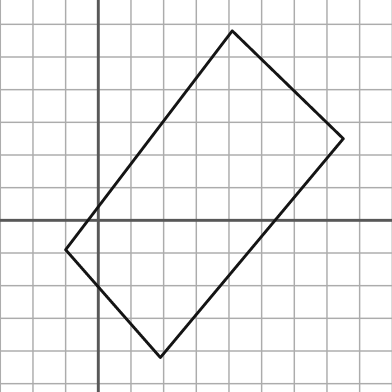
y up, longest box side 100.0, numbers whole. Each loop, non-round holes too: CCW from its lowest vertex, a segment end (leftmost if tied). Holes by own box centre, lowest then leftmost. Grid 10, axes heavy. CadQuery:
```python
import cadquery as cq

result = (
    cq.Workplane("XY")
    .moveTo(19.0, -42.0)
    .lineTo(75.0, 25.0)
    .lineTo(41.0, 58.0)
    .lineTo(-10.0, -9.0)
    .close()
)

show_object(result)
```